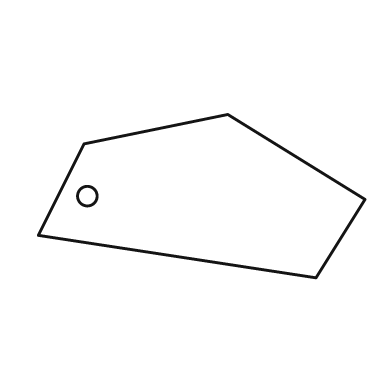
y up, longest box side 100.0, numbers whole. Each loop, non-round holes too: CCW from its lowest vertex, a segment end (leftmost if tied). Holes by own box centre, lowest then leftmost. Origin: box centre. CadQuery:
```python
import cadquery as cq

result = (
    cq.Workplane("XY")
    .moveTo(35.0, -25.0)
    .lineTo(50.0, -1.0)
    .lineTo(8.0, 25.0)
    .lineTo(-36.0, 16.0)
    .lineTo(-50.0, -12.0)
    .close()
    .moveTo(-35.0, 0.0)
    .circle(3.0)
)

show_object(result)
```